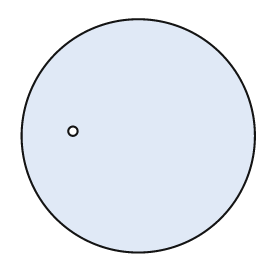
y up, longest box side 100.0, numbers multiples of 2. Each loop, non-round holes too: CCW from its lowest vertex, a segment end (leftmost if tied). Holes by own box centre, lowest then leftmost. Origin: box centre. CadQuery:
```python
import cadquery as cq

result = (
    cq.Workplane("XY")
    .moveTo(0.0, 0.0)
    .circle(50.0)
    .moveTo(-28.0, 2.0)
    .circle(2.0)
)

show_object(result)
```